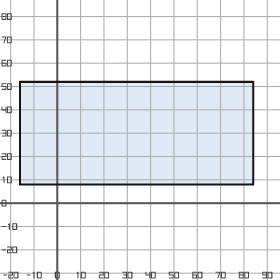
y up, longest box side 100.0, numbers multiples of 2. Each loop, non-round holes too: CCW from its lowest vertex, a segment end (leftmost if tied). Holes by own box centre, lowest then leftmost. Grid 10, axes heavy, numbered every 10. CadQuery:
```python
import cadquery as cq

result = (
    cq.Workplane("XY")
    .moveTo(-16.0, 8.0)
    .lineTo(84.0, 8.0)
    .lineTo(84.0, 52.0)
    .lineTo(-16.0, 52.0)
    .close()
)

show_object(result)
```